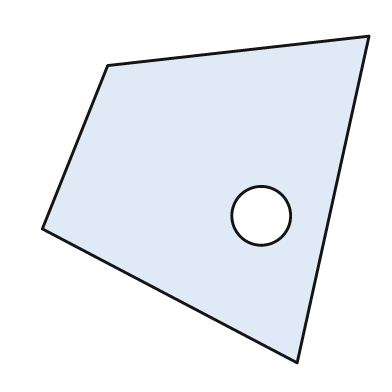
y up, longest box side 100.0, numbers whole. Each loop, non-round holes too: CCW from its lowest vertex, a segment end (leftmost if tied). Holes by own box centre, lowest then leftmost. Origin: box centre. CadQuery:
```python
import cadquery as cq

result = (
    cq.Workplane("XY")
    .moveTo(28.0, -50.0)
    .lineTo(50.0, 50.0)
    .lineTo(-30.0, 41.0)
    .lineTo(-50.0, -9.0)
    .close()
    .moveTo(17.0, -5.0)
    .circle(9.0)
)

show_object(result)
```